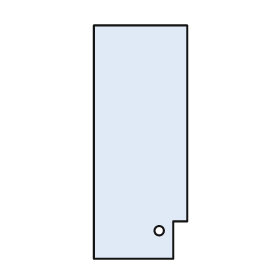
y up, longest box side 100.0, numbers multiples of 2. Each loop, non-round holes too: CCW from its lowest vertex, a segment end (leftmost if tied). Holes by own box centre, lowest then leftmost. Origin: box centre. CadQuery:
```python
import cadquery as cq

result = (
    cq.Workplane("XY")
    .moveTo(-20.0, -50.0)
    .lineTo(14.0, -50.0)
    .lineTo(14.0, -34.0)
    .lineTo(20.0, -34.0)
    .lineTo(20.0, 50.0)
    .lineTo(-20.0, 50.0)
    .close()
    .moveTo(8.0, -38.0)
    .circle(2.0)
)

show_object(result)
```